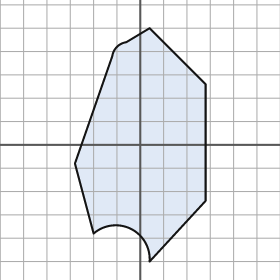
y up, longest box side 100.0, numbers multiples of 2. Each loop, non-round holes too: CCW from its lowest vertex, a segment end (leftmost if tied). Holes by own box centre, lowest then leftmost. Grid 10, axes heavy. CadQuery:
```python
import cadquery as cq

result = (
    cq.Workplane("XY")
    .moveTo(4.0, -50.0)
    .lineTo(28.0, -24.0)
    .lineTo(28.0, 26.0)
    .lineTo(4.0, 50.0)
    .lineTo(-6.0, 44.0)
    .threePointArc((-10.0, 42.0), (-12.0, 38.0))
    .lineTo(-28.0, -8.0)
    .lineTo(-20.0, -38.0)
    .threePointArc((-4.0, -36.0), (4.0, -50.0))
    .close()
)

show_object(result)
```